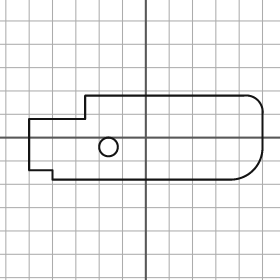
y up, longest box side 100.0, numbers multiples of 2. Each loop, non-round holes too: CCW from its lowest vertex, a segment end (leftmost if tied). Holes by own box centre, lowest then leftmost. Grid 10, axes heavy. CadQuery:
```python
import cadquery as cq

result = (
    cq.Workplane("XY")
    .moveTo(-40.0, -18.0)
    .lineTo(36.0, -18.0)
    .threePointArc((46.0, -14.0), (50.0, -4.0))
    .lineTo(50.0, 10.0)
    .threePointArc((48.0, 16.0), (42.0, 18.0))
    .lineTo(-26.0, 18.0)
    .lineTo(-26.0, 8.0)
    .lineTo(-50.0, 8.0)
    .lineTo(-50.0, -14.0)
    .lineTo(-40.0, -14.0)
    .close()
    .moveTo(-16.0, -4.0)
    .circle(4.0)
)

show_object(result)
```